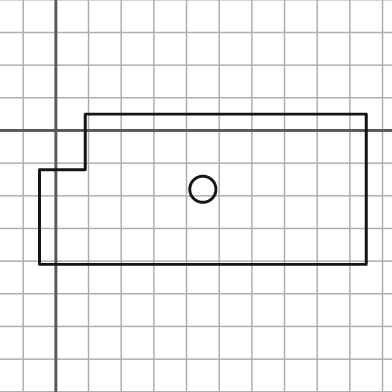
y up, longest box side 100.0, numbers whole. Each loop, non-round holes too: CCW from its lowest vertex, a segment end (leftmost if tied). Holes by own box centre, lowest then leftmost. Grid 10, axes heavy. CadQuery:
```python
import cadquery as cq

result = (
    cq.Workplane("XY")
    .moveTo(-5.0, -41.0)
    .lineTo(95.0, -41.0)
    .lineTo(95.0, 5.0)
    .lineTo(9.0, 5.0)
    .lineTo(9.0, -12.0)
    .lineTo(-5.0, -12.0)
    .close()
    .moveTo(45.0, -18.0)
    .circle(4.0)
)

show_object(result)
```